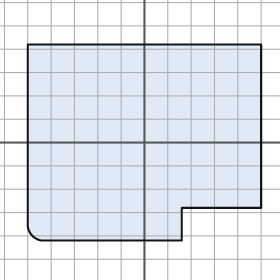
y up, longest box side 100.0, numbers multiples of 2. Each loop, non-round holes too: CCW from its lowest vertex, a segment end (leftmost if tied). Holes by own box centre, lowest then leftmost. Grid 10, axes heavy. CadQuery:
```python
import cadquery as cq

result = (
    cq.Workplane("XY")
    .moveTo(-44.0, -42.0)
    .lineTo(16.0, -42.0)
    .lineTo(16.0, -28.0)
    .lineTo(50.0, -28.0)
    .lineTo(50.0, 42.0)
    .lineTo(-50.0, 42.0)
    .lineTo(-50.0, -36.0)
    .threePointArc((-48.0, -40.0), (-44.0, -42.0))
    .close()
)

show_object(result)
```